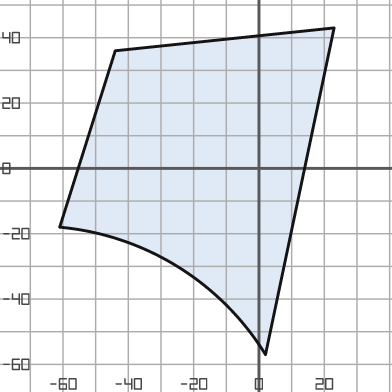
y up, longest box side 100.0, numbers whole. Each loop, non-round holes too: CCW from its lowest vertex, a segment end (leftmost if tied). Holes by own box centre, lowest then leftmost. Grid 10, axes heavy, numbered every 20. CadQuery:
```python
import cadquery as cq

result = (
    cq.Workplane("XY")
    .moveTo(2.0, -57.0)
    .lineTo(23.0, 43.0)
    .lineTo(-44.0, 36.0)
    .lineTo(-61.0, -18.0)
    .threePointArc((-25.0, -30.0), (2.0, -57.0))
    .close()
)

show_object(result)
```